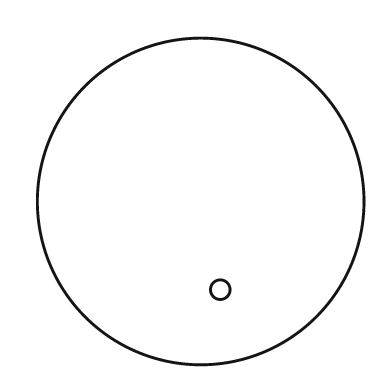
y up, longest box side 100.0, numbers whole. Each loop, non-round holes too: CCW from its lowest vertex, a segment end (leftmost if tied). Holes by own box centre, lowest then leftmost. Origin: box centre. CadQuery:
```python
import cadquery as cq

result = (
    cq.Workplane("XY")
    .moveTo(0.0, 0.0)
    .circle(50.0)
    .moveTo(6.0, -27.0)
    .circle(3.0)
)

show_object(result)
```